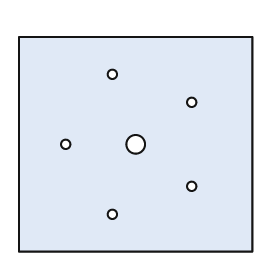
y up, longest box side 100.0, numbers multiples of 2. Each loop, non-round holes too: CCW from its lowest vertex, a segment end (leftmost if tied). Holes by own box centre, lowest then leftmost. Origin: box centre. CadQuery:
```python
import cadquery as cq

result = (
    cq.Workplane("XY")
    .moveTo(-50.0, -46.0)
    .lineTo(50.0, -46.0)
    .lineTo(50.0, 46.0)
    .lineTo(-50.0, 46.0)
    .close()
    .moveTo(-10.0, -30.0)
    .circle(2.0)
    .moveTo(24.0, -18.0)
    .circle(2.0)
    .moveTo(-30.0, 0.0)
    .circle(2.0)
    .moveTo(0.0, 0.0)
    .circle(4.0)
    .moveTo(24.0, 18.0)
    .circle(2.0)
    .moveTo(-10.0, 30.0)
    .circle(2.0)
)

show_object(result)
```